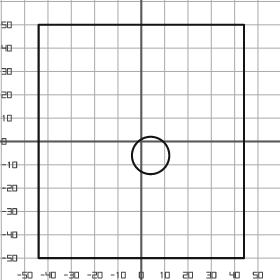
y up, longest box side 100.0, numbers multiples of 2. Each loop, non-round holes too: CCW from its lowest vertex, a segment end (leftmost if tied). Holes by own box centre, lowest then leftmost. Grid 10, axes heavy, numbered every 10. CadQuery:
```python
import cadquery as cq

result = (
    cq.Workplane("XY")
    .moveTo(-44.0, -50.0)
    .lineTo(44.0, -50.0)
    .lineTo(44.0, 50.0)
    .lineTo(-44.0, 50.0)
    .close()
    .moveTo(4.0, -6.0)
    .circle(8.0)
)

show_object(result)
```